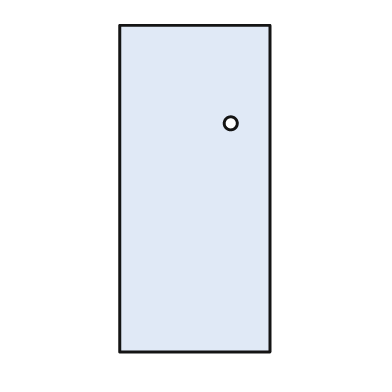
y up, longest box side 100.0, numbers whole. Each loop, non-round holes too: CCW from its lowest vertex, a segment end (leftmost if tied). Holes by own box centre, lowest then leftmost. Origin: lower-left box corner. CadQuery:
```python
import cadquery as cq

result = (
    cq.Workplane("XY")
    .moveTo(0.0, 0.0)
    .lineTo(46.0, 0.0)
    .lineTo(46.0, 100.0)
    .lineTo(0.0, 100.0)
    .close()
    .moveTo(34.0, 70.0)
    .circle(2.0)
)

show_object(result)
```